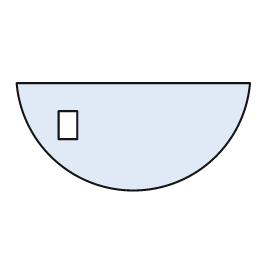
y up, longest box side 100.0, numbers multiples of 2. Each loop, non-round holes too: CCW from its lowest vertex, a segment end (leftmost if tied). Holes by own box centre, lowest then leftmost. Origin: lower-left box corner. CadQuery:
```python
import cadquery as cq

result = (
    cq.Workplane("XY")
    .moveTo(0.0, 46.0)
    .threePointArc((50.0, 0.0), (100.0, 46.0))
    .close()
    .moveTo(18.0, 22.0)
    .lineTo(26.0, 22.0)
    .lineTo(26.0, 34.0)
    .lineTo(18.0, 34.0)
    .close()
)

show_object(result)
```